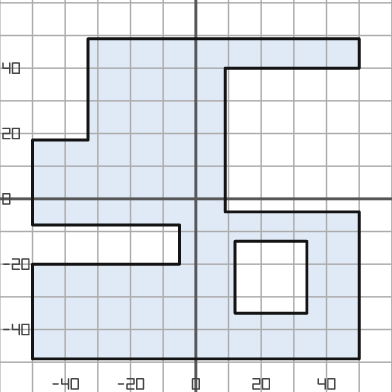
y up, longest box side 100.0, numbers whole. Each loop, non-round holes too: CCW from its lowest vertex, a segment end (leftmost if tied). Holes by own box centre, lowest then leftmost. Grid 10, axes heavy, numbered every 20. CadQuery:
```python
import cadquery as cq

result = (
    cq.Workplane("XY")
    .moveTo(-50.0, -49.0)
    .lineTo(50.0, -49.0)
    .lineTo(50.0, -4.0)
    .lineTo(9.0, -4.0)
    .lineTo(9.0, 40.0)
    .lineTo(50.0, 40.0)
    .lineTo(50.0, 49.0)
    .lineTo(-33.0, 49.0)
    .lineTo(-33.0, 18.0)
    .lineTo(-50.0, 18.0)
    .lineTo(-50.0, -8.0)
    .lineTo(-5.0, -8.0)
    .lineTo(-5.0, -20.0)
    .lineTo(-50.0, -20.0)
    .close()
    .moveTo(12.0, -35.0)
    .lineTo(34.0, -35.0)
    .lineTo(34.0, -13.0)
    .lineTo(12.0, -13.0)
    .close()
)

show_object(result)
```